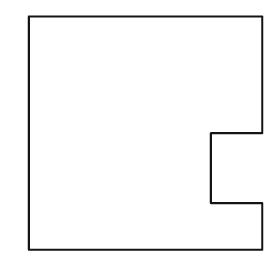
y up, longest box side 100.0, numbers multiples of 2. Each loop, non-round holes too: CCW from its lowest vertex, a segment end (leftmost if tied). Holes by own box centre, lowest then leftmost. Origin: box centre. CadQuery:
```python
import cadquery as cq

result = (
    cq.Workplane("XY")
    .moveTo(-50.0, -50.0)
    .lineTo(50.0, -50.0)
    .lineTo(50.0, -30.0)
    .lineTo(28.0, -30.0)
    .lineTo(28.0, 0.0)
    .lineTo(50.0, 0.0)
    .lineTo(50.0, 50.0)
    .lineTo(-50.0, 50.0)
    .close()
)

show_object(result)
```